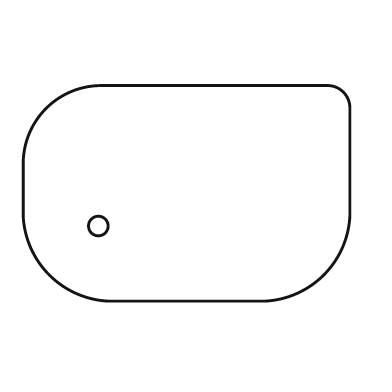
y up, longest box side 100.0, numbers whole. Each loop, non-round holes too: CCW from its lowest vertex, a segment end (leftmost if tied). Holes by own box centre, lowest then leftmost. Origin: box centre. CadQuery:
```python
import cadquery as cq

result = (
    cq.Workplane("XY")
    .moveTo(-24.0, -33.0)
    .lineTo(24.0, -33.0)
    .threePointArc((42.0, -25.0), (50.0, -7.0))
    .lineTo(50.0, 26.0)
    .threePointArc((48.0, 31.0), (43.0, 33.0))
    .lineTo(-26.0, 33.0)
    .threePointArc((-43.0, 26.0), (-50.0, 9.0))
    .lineTo(-50.0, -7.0)
    .threePointArc((-42.0, -25.0), (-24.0, -33.0))
    .close()
    .moveTo(-27.0, -10.0)
    .circle(3.0)
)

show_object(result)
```